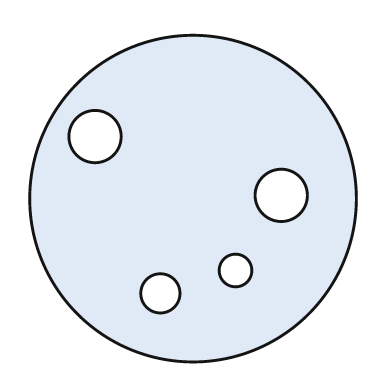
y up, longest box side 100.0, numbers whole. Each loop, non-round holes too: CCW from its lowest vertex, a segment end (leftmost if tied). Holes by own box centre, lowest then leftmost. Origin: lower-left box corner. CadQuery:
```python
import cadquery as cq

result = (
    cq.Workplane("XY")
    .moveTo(50.0, 50.0)
    .circle(50.0)
    .moveTo(40.0, 21.0)
    .circle(6.0)
    .moveTo(63.0, 28.0)
    .circle(5.0)
    .moveTo(77.0, 51.0)
    .circle(8.0)
    .moveTo(20.0, 69.0)
    .circle(8.0)
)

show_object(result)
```